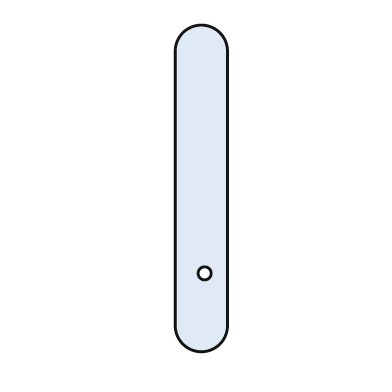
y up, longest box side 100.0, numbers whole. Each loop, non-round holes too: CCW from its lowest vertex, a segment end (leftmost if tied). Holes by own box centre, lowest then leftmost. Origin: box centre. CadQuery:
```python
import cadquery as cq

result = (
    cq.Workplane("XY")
    .moveTo(-8.0, -42.0)
    .threePointArc((0.0, -50.0), (8.0, -42.0))
    .lineTo(8.0, 42.0)
    .threePointArc((0.0, 50.0), (-8.0, 42.0))
    .close()
    .moveTo(1.0, -26.0)
    .circle(2.0)
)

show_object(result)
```